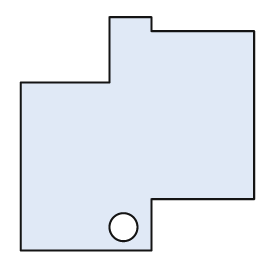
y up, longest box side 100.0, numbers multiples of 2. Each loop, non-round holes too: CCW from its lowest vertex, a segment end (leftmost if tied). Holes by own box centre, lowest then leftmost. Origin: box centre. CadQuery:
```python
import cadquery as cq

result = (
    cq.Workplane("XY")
    .moveTo(-50.0, -50.0)
    .lineTo(6.0, -50.0)
    .lineTo(6.0, -28.0)
    .lineTo(50.0, -28.0)
    .lineTo(50.0, 44.0)
    .lineTo(6.0, 44.0)
    .lineTo(6.0, 50.0)
    .lineTo(-12.0, 50.0)
    .lineTo(-12.0, 22.0)
    .lineTo(-50.0, 22.0)
    .close()
    .moveTo(-6.0, -40.0)
    .circle(6.0)
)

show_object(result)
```